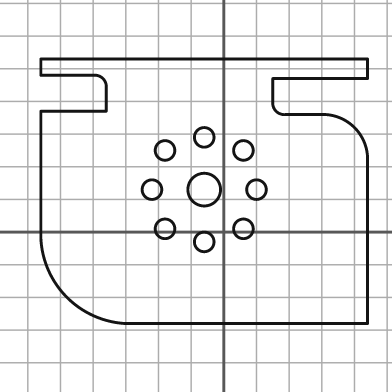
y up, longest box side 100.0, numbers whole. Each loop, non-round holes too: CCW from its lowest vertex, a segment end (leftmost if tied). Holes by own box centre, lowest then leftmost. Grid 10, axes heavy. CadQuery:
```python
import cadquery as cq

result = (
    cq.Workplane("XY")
    .moveTo(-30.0, -28.0)
    .lineTo(44.0, -28.0)
    .lineTo(44.0, 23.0)
    .threePointArc((40.0, 32.0), (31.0, 36.0))
    .lineTo(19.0, 36.0)
    .threePointArc((16.0, 37.0), (15.0, 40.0))
    .lineTo(15.0, 47.0)
    .lineTo(44.0, 47.0)
    .lineTo(44.0, 53.0)
    .lineTo(-56.0, 53.0)
    .lineTo(-56.0, 48.0)
    .lineTo(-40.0, 48.0)
    .threePointArc((-37.0, 47.0), (-36.0, 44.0))
    .lineTo(-36.0, 37.0)
    .lineTo(-56.0, 37.0)
    .lineTo(-56.0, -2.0)
    .threePointArc((-48.0, -20.0), (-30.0, -28.0))
    .close()
    .moveTo(-6.0, -3.0)
    .circle(3.0)
    .moveTo(-18.0, 1.0)
    .circle(3.0)
    .moveTo(6.0, 1.0)
    .circle(3.0)
    .moveTo(-22.0, 13.0)
    .circle(3.0)
    .moveTo(-6.0, 13.0)
    .circle(5.0)
    .moveTo(10.0, 13.0)
    .circle(3.0)
    .moveTo(-18.0, 25.0)
    .circle(3.0)
    .moveTo(6.0, 25.0)
    .circle(3.0)
    .moveTo(-6.0, 29.0)
    .circle(3.0)
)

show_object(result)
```